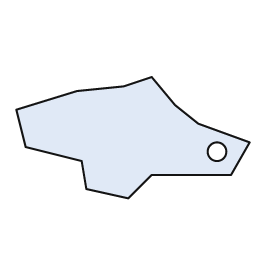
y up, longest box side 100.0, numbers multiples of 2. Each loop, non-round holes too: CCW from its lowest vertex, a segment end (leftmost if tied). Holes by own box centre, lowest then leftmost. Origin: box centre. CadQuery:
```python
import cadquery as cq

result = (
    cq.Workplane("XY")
    .moveTo(-2.0, -26.0)
    .lineTo(8.0, -16.0)
    .lineTo(42.0, -16.0)
    .lineTo(50.0, -2.0)
    .lineTo(28.0, 6.0)
    .lineTo(18.0, 14.0)
    .lineTo(8.0, 26.0)
    .lineTo(-4.0, 22.0)
    .lineTo(-24.0, 20.0)
    .lineTo(-50.0, 12.0)
    .lineTo(-46.0, -4.0)
    .lineTo(-22.0, -10.0)
    .lineTo(-20.0, -22.0)
    .close()
    .moveTo(36.0, -6.0)
    .circle(4.0)
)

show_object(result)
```